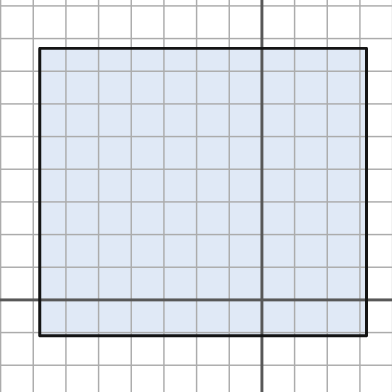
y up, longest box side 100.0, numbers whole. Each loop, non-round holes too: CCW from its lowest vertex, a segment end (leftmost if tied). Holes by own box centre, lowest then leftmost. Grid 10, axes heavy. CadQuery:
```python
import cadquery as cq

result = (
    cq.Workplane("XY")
    .moveTo(-68.0, -11.0)
    .lineTo(32.0, -11.0)
    .lineTo(32.0, 77.0)
    .lineTo(-68.0, 77.0)
    .close()
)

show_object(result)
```